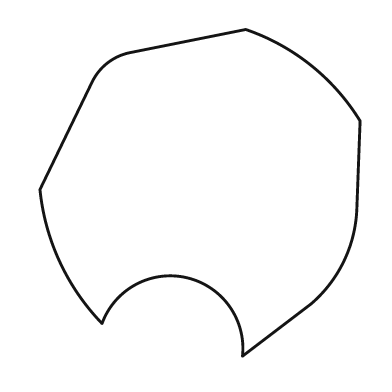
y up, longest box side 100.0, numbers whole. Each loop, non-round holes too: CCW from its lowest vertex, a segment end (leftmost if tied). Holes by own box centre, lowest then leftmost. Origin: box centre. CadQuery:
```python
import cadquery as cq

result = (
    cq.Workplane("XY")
    .moveTo(13.0, -50.0)
    .lineTo(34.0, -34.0)
    .threePointArc((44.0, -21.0), (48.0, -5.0))
    .lineTo(49.0, 22.0)
    .threePointArc((34.0, 39.0), (14.0, 50.0))
    .lineTo(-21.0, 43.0)
    .threePointArc((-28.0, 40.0), (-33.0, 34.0))
    .lineTo(-49.0, 1.0)
    .threePointArc((-43.0, -21.0), (-30.0, -40.0))
    .threePointArc((-4.0, -26.0), (13.0, -50.0))
    .close()
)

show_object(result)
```